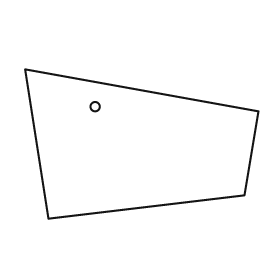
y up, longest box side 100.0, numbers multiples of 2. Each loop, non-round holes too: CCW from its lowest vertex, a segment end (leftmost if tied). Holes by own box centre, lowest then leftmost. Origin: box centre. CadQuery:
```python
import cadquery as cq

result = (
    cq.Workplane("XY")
    .moveTo(-40.0, -32.0)
    .lineTo(44.0, -22.0)
    .lineTo(50.0, 14.0)
    .lineTo(-50.0, 32.0)
    .close()
    .moveTo(-20.0, 16.0)
    .circle(2.0)
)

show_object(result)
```